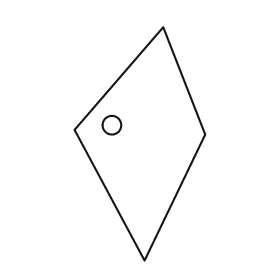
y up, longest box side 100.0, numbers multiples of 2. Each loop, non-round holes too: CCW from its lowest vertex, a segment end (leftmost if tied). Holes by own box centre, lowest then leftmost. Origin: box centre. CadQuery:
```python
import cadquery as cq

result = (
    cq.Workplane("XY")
    .moveTo(2.0, -50.0)
    .lineTo(28.0, 4.0)
    .lineTo(10.0, 50.0)
    .lineTo(-28.0, 6.0)
    .close()
    .moveTo(-12.0, 8.0)
    .circle(4.0)
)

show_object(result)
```